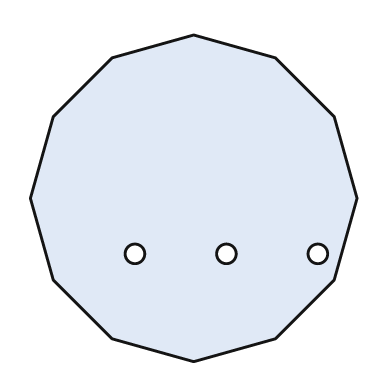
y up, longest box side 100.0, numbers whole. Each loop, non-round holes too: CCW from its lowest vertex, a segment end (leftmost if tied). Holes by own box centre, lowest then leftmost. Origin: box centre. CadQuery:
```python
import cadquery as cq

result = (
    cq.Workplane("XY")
    .moveTo(0.0, -50.0)
    .lineTo(25.0, -43.0)
    .lineTo(43.0, -25.0)
    .lineTo(50.0, 0.0)
    .lineTo(43.0, 25.0)
    .lineTo(25.0, 43.0)
    .lineTo(0.0, 50.0)
    .lineTo(-25.0, 43.0)
    .lineTo(-43.0, 25.0)
    .lineTo(-50.0, 0.0)
    .lineTo(-43.0, -25.0)
    .lineTo(-25.0, -43.0)
    .close()
    .moveTo(-18.0, -17.0)
    .circle(3.0)
    .moveTo(10.0, -17.0)
    .circle(3.0)
    .moveTo(38.0, -17.0)
    .circle(3.0)
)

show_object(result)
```